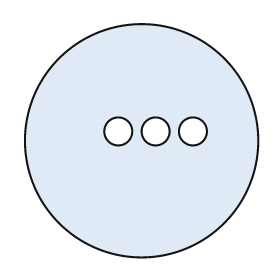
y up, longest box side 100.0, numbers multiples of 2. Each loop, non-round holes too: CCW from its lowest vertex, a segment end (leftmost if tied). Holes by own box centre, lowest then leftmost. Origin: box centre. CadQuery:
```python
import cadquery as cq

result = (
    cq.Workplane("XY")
    .moveTo(0.0, 0.0)
    .circle(50.0)
    .moveTo(-10.0, 4.0)
    .circle(6.0)
    .moveTo(6.0, 4.0)
    .circle(6.0)
    .moveTo(22.0, 4.0)
    .circle(6.0)
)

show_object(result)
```